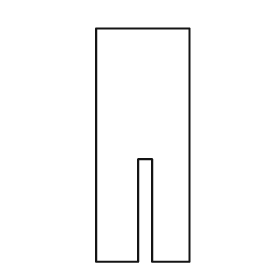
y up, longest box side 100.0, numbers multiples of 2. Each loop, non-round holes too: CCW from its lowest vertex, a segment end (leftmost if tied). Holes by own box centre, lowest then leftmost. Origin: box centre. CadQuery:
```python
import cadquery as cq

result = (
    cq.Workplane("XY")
    .moveTo(-20.0, -50.0)
    .lineTo(-2.0, -50.0)
    .lineTo(-2.0, -6.0)
    .lineTo(4.0, -6.0)
    .lineTo(4.0, -50.0)
    .lineTo(20.0, -50.0)
    .lineTo(20.0, 50.0)
    .lineTo(-20.0, 50.0)
    .close()
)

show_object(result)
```